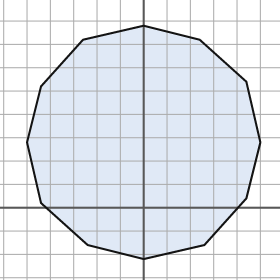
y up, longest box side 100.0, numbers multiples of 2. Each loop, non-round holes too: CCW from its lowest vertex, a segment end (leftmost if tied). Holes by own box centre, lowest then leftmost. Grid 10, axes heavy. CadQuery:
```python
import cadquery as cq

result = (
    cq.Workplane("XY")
    .moveTo(0.0, -22.0)
    .lineTo(26.0, -16.0)
    .lineTo(44.0, 4.0)
    .lineTo(50.0, 28.0)
    .lineTo(44.0, 54.0)
    .lineTo(24.0, 72.0)
    .lineTo(0.0, 78.0)
    .lineTo(-26.0, 72.0)
    .lineTo(-44.0, 52.0)
    .lineTo(-50.0, 28.0)
    .lineTo(-44.0, 2.0)
    .lineTo(-24.0, -16.0)
    .close()
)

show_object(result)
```